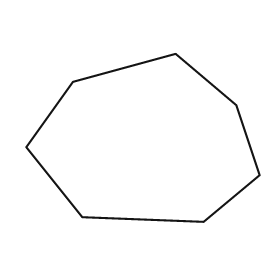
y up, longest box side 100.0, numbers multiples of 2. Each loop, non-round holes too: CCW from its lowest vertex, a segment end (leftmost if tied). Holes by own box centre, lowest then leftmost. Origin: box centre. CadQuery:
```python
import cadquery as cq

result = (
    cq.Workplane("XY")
    .moveTo(26.0, -36.0)
    .lineTo(50.0, -16.0)
    .lineTo(40.0, 14.0)
    .lineTo(14.0, 36.0)
    .lineTo(-30.0, 24.0)
    .lineTo(-50.0, -4.0)
    .lineTo(-26.0, -34.0)
    .close()
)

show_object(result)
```